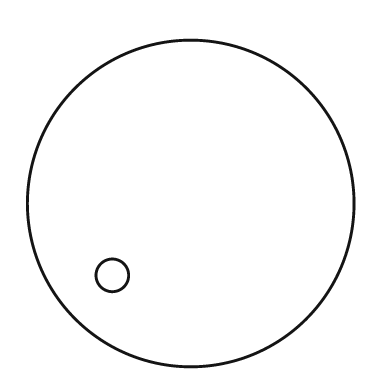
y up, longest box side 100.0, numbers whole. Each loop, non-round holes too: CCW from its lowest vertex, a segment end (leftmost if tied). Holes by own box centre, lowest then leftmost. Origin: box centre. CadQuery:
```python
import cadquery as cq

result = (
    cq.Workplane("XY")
    .moveTo(0.0, 0.0)
    .circle(50.0)
    .moveTo(-24.0, -22.0)
    .circle(5.0)
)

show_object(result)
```